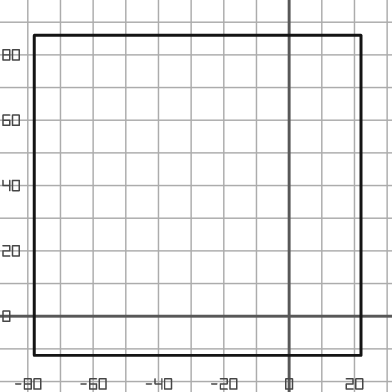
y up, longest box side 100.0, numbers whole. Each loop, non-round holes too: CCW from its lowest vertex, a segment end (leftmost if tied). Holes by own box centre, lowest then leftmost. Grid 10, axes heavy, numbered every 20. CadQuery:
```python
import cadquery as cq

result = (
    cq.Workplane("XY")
    .moveTo(-78.0, -12.0)
    .lineTo(22.0, -12.0)
    .lineTo(22.0, 86.0)
    .lineTo(-78.0, 86.0)
    .close()
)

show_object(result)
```